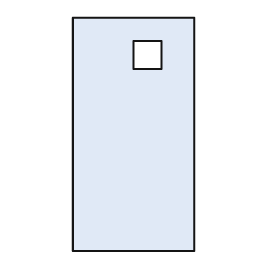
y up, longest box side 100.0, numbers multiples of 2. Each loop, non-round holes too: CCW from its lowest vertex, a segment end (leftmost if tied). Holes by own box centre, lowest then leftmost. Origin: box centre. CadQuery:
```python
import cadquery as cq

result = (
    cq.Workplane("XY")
    .moveTo(-26.0, -50.0)
    .lineTo(26.0, -50.0)
    .lineTo(26.0, 50.0)
    .lineTo(-26.0, 50.0)
    .close()
    .moveTo(0.0, 28.0)
    .lineTo(12.0, 28.0)
    .lineTo(12.0, 40.0)
    .lineTo(0.0, 40.0)
    .close()
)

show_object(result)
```